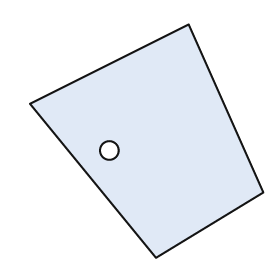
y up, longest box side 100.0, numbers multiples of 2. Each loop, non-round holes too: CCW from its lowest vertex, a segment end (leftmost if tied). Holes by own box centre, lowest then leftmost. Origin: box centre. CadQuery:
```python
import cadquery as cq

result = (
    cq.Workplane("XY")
    .moveTo(4.0, -50.0)
    .lineTo(50.0, -22.0)
    .lineTo(18.0, 50.0)
    .lineTo(-50.0, 16.0)
    .close()
    .moveTo(-16.0, -4.0)
    .circle(4.0)
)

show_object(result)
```